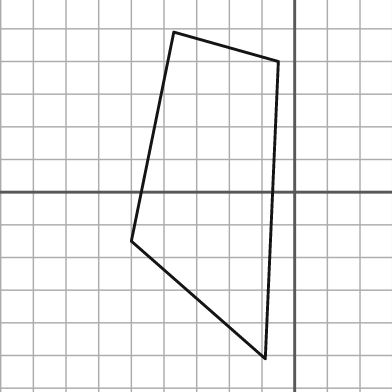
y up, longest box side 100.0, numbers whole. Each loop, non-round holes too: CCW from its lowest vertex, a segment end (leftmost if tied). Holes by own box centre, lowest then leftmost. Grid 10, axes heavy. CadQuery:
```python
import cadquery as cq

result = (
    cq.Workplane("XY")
    .moveTo(-9.0, -51.0)
    .lineTo(-5.0, 40.0)
    .lineTo(-37.0, 49.0)
    .lineTo(-50.0, -15.0)
    .close()
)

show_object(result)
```